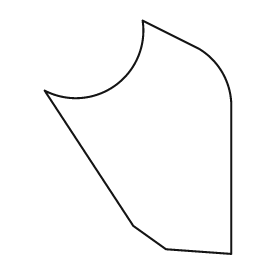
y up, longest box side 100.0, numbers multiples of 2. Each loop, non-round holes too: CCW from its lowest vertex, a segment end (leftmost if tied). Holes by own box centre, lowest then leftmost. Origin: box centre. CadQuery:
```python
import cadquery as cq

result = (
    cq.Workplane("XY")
    .moveTo(40.0, -50.0)
    .lineTo(40.0, 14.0)
    .threePointArc((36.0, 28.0), (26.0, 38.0))
    .lineTo(2.0, 50.0)
    .threePointArc((-10.0, 22.0), (-40.0, 20.0))
    .lineTo(-2.0, -38.0)
    .lineTo(12.0, -48.0)
    .close()
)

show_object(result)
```